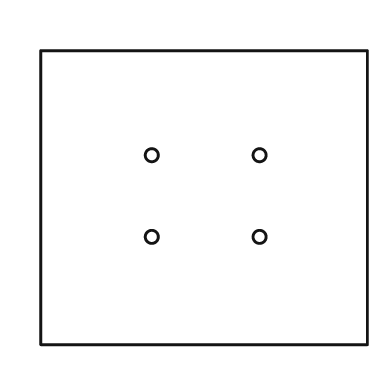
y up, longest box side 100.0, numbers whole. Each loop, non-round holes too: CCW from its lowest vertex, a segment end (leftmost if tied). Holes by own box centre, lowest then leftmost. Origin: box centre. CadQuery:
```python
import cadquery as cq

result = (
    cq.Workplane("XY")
    .moveTo(-50.0, -45.0)
    .lineTo(50.0, -45.0)
    .lineTo(50.0, 45.0)
    .lineTo(-50.0, 45.0)
    .close()
    .moveTo(-16.0, -12.0)
    .circle(2.0)
    .moveTo(17.0, -12.0)
    .circle(2.0)
    .moveTo(-16.0, 13.0)
    .circle(2.0)
    .moveTo(17.0, 13.0)
    .circle(2.0)
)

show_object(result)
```